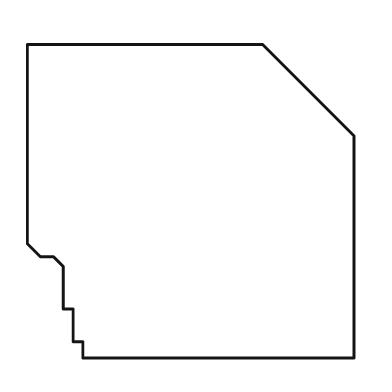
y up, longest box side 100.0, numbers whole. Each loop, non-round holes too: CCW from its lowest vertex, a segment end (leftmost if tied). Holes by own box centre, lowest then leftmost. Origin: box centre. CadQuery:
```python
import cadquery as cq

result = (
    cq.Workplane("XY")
    .moveTo(-33.0, -48.0)
    .lineTo(50.0, -48.0)
    .lineTo(50.0, 20.0)
    .lineTo(22.0, 48.0)
    .lineTo(-50.0, 48.0)
    .lineTo(-50.0, -13.0)
    .lineTo(-46.0, -17.0)
    .lineTo(-42.0, -17.0)
    .lineTo(-39.0, -20.0)
    .lineTo(-39.0, -33.0)
    .lineTo(-36.0, -33.0)
    .lineTo(-36.0, -43.0)
    .lineTo(-33.0, -43.0)
    .close()
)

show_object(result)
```